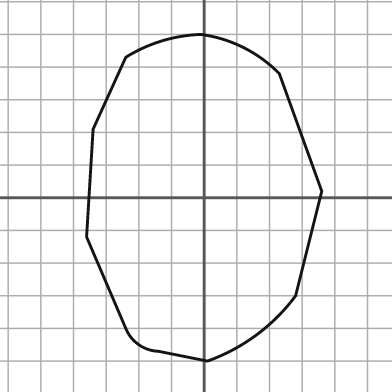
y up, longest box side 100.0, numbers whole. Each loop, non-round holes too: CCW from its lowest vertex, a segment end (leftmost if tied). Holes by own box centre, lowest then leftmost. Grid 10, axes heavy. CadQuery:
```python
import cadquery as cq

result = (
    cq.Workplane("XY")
    .moveTo(1.0, -50.0)
    .threePointArc((16.0, -42.0), (28.0, -30.0))
    .lineTo(36.0, 2.0)
    .lineTo(23.0, 38.0)
    .threePointArc((12.0, 46.0), (-1.0, 50.0))
    .threePointArc((-13.0, 48.0), (-24.0, 43.0))
    .lineTo(-34.0, 21.0)
    .lineTo(-36.0, -12.0)
    .lineTo(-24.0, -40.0)
    .threePointArc((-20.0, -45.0), (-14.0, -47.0))
    .close()
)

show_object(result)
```